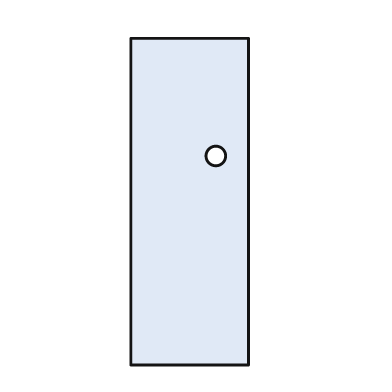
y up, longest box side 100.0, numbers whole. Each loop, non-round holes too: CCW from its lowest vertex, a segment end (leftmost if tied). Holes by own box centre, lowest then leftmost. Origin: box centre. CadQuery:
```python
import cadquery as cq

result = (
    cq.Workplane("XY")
    .moveTo(-18.0, -50.0)
    .lineTo(18.0, -50.0)
    .lineTo(18.0, 50.0)
    .lineTo(-18.0, 50.0)
    .close()
    .moveTo(8.0, 14.0)
    .circle(3.0)
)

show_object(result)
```